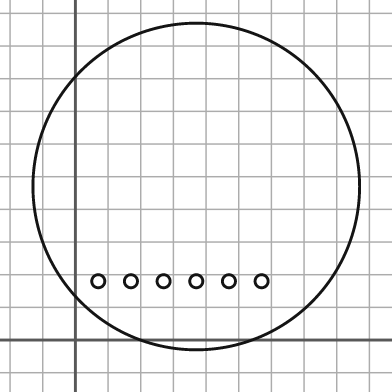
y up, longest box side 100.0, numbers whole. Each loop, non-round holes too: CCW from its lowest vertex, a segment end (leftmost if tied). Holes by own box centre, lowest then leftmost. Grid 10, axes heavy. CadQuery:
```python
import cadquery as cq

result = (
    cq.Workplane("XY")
    .moveTo(37.0, 47.0)
    .circle(50.0)
    .moveTo(7.0, 18.0)
    .circle(2.0)
    .moveTo(17.0, 18.0)
    .circle(2.0)
    .moveTo(27.0, 18.0)
    .circle(2.0)
    .moveTo(37.0, 18.0)
    .circle(2.0)
    .moveTo(47.0, 18.0)
    .circle(2.0)
    .moveTo(57.0, 18.0)
    .circle(2.0)
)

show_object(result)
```